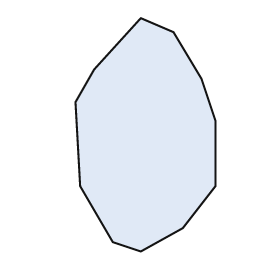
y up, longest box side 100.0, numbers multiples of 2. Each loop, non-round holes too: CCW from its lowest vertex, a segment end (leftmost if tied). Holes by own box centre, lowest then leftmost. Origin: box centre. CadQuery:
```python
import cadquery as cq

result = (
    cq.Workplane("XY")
    .moveTo(-2.0, -50.0)
    .lineTo(16.0, -40.0)
    .lineTo(30.0, -22.0)
    .lineTo(30.0, 6.0)
    .lineTo(24.0, 24.0)
    .lineTo(12.0, 44.0)
    .lineTo(-2.0, 50.0)
    .lineTo(-22.0, 28.0)
    .lineTo(-30.0, 14.0)
    .lineTo(-28.0, -22.0)
    .lineTo(-14.0, -46.0)
    .close()
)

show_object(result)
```